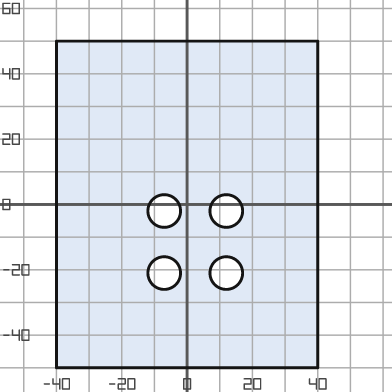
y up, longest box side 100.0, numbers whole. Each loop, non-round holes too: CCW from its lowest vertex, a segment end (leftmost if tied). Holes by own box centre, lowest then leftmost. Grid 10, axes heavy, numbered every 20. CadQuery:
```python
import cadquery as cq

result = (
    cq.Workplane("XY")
    .moveTo(-40.0, -50.0)
    .lineTo(40.0, -50.0)
    .lineTo(40.0, 50.0)
    .lineTo(-40.0, 50.0)
    .close()
    .moveTo(-7.0, -21.0)
    .circle(5.0)
    .moveTo(12.0, -21.0)
    .circle(5.0)
    .moveTo(-7.0, -2.0)
    .circle(5.0)
    .moveTo(12.0, -2.0)
    .circle(5.0)
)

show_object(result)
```